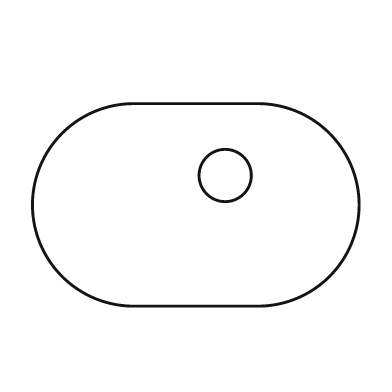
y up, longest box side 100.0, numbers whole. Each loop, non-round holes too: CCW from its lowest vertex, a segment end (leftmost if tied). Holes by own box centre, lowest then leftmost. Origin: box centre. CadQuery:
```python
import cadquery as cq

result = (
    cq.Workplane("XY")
    .moveTo(-19.0, -31.0)
    .lineTo(19.0, -31.0)
    .threePointArc((50.0, 0.0), (19.0, 31.0))
    .lineTo(-19.0, 31.0)
    .threePointArc((-50.0, 0.0), (-19.0, -31.0))
    .close()
    .moveTo(9.0, 9.0)
    .circle(8.0)
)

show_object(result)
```